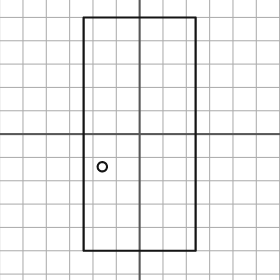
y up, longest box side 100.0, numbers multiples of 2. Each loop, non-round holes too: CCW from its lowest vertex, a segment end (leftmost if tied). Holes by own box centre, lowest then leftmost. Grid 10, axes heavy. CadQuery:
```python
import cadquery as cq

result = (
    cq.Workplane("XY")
    .moveTo(-24.0, -50.0)
    .lineTo(24.0, -50.0)
    .lineTo(24.0, 50.0)
    .lineTo(-24.0, 50.0)
    .close()
    .moveTo(-16.0, -14.0)
    .circle(2.0)
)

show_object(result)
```